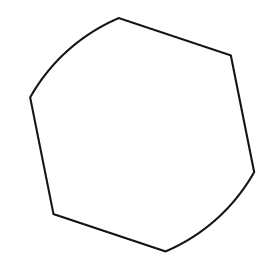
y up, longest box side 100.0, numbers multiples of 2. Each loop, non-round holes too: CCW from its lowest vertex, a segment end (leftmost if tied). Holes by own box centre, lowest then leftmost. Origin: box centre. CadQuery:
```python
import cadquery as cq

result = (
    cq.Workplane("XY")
    .moveTo(10.0, -50.0)
    .threePointArc((32.0, -36.0), (48.0, -16.0))
    .lineTo(38.0, 34.0)
    .lineTo(-10.0, 50.0)
    .threePointArc((-32.0, 36.0), (-48.0, 16.0))
    .lineTo(-38.0, -34.0)
    .close()
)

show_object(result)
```